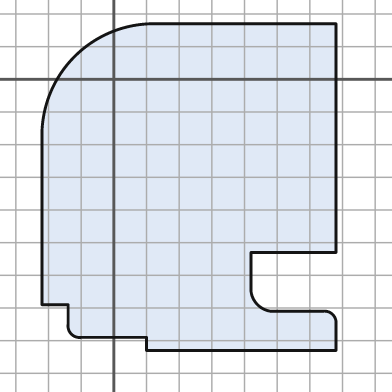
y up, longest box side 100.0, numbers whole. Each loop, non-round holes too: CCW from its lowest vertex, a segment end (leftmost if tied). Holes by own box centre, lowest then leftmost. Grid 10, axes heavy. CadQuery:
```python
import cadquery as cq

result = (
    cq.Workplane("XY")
    .moveTo(10.0, -83.0)
    .lineTo(68.0, -83.0)
    .lineTo(68.0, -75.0)
    .threePointArc((67.0, -72.0), (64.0, -71.0))
    .lineTo(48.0, -71.0)
    .threePointArc((44.0, -69.0), (42.0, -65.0))
    .lineTo(42.0, -53.0)
    .lineTo(68.0, -53.0)
    .lineTo(68.0, 17.0)
    .lineTo(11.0, 17.0)
    .threePointArc((-12.0, 7.0), (-22.0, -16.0))
    .lineTo(-22.0, -69.0)
    .lineTo(-14.0, -69.0)
    .lineTo(-14.0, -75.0)
    .threePointArc((-13.0, -78.0), (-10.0, -79.0))
    .lineTo(10.0, -79.0)
    .close()
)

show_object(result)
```